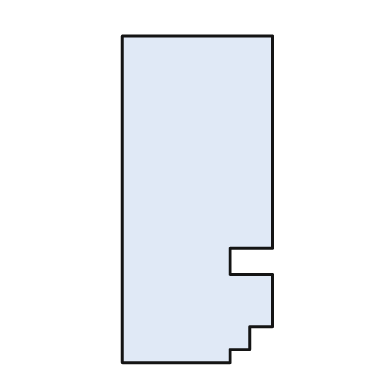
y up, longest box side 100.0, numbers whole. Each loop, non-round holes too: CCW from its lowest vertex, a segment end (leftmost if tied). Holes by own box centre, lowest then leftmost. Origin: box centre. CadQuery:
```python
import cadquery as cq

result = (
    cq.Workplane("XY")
    .moveTo(-23.0, -50.0)
    .lineTo(10.0, -50.0)
    .lineTo(10.0, -46.0)
    .lineTo(16.0, -46.0)
    .lineTo(16.0, -39.0)
    .lineTo(23.0, -39.0)
    .lineTo(23.0, -23.0)
    .lineTo(10.0, -23.0)
    .lineTo(10.0, -15.0)
    .lineTo(23.0, -15.0)
    .lineTo(23.0, 50.0)
    .lineTo(-23.0, 50.0)
    .close()
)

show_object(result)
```